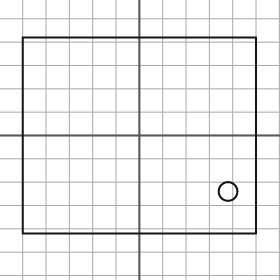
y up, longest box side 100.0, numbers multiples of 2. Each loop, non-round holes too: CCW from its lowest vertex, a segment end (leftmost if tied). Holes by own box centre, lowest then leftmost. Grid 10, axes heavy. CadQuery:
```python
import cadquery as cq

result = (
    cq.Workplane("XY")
    .moveTo(-50.0, -42.0)
    .lineTo(50.0, -42.0)
    .lineTo(50.0, 42.0)
    .lineTo(-50.0, 42.0)
    .close()
    .moveTo(38.0, -24.0)
    .circle(4.0)
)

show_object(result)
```